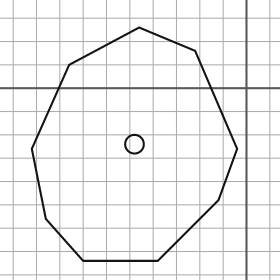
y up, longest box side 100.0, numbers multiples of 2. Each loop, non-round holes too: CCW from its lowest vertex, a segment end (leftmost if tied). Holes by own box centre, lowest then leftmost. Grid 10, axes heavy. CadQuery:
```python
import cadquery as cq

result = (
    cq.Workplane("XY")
    .moveTo(-70.0, -74.0)
    .lineTo(-38.0, -74.0)
    .lineTo(-12.0, -48.0)
    .lineTo(-4.0, -26.0)
    .lineTo(-22.0, 16.0)
    .lineTo(-46.0, 26.0)
    .lineTo(-76.0, 10.0)
    .lineTo(-92.0, -26.0)
    .lineTo(-86.0, -56.0)
    .close()
    .moveTo(-48.0, -24.0)
    .circle(4.0)
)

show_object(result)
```